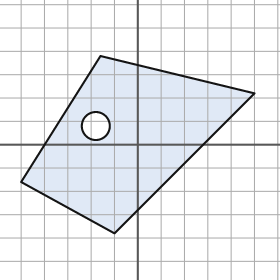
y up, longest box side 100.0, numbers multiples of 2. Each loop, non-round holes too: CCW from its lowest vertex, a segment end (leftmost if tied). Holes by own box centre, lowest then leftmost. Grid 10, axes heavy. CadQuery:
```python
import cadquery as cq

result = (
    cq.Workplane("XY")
    .moveTo(-10.0, -38.0)
    .lineTo(50.0, 22.0)
    .lineTo(-16.0, 38.0)
    .lineTo(-50.0, -16.0)
    .close()
    .moveTo(-18.0, 8.0)
    .circle(6.0)
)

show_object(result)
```